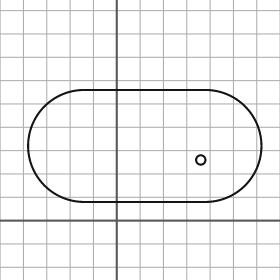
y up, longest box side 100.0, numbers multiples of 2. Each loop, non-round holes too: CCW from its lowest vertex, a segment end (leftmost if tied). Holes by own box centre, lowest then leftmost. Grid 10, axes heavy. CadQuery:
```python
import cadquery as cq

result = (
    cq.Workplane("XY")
    .moveTo(-14.0, 8.0)
    .lineTo(38.0, 8.0)
    .threePointArc((62.0, 32.0), (38.0, 56.0))
    .lineTo(-14.0, 56.0)
    .threePointArc((-38.0, 32.0), (-14.0, 8.0))
    .close()
    .moveTo(36.0, 26.0)
    .circle(2.0)
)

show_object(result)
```